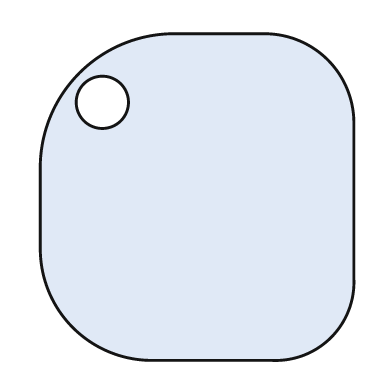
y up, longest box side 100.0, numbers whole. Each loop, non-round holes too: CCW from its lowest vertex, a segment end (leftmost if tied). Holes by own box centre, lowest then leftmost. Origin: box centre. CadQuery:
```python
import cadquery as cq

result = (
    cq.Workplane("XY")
    .moveTo(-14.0, -50.0)
    .lineTo(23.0, -50.0)
    .threePointArc((41.0, -43.0), (48.0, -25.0))
    .lineTo(48.0, 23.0)
    .threePointArc((40.0, 42.0), (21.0, 50.0))
    .lineTo(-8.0, 50.0)
    .threePointArc((-36.0, 38.0), (-48.0, 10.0))
    .lineTo(-48.0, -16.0)
    .threePointArc((-38.0, -40.0), (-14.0, -50.0))
    .close()
    .moveTo(-29.0, 29.0)
    .circle(8.0)
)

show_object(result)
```